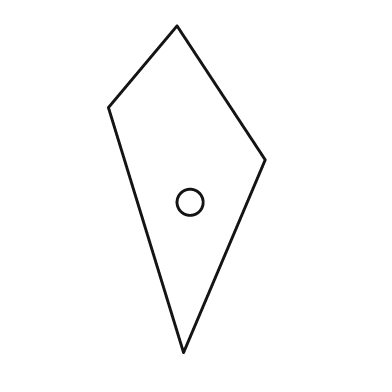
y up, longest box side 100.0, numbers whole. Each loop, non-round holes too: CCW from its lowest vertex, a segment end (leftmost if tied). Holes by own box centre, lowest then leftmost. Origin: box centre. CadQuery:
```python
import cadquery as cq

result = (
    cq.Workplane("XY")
    .moveTo(-1.0, -50.0)
    .lineTo(24.0, 9.0)
    .lineTo(-3.0, 50.0)
    .lineTo(-24.0, 25.0)
    .close()
    .moveTo(1.0, -4.0)
    .circle(4.0)
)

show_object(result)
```